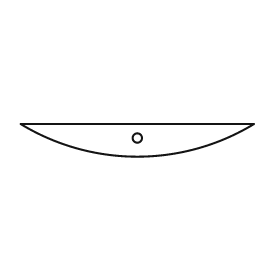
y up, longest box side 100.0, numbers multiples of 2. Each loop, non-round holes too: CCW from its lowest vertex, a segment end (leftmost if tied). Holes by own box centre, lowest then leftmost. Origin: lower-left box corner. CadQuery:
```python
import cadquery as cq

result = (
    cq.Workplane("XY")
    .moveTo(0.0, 14.0)
    .threePointArc((50.0, 0.0), (100.0, 14.0))
    .close()
    .moveTo(50.0, 8.0)
    .circle(2.0)
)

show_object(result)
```